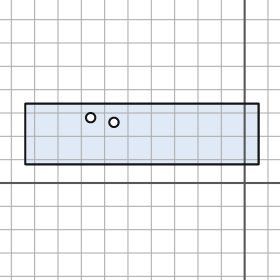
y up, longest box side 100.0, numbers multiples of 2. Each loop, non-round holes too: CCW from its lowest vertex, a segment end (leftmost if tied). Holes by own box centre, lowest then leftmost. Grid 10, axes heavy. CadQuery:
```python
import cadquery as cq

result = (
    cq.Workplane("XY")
    .moveTo(-94.0, 8.0)
    .lineTo(6.0, 8.0)
    .lineTo(6.0, 34.0)
    .lineTo(-94.0, 34.0)
    .close()
    .moveTo(-56.0, 26.0)
    .circle(2.0)
    .moveTo(-66.0, 28.0)
    .circle(2.0)
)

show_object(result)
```